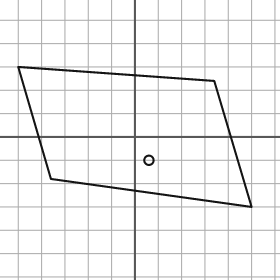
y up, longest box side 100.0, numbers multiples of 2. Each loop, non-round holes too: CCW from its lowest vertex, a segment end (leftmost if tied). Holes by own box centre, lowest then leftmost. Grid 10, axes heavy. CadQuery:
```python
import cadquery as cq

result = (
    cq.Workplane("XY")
    .moveTo(50.0, -30.0)
    .lineTo(34.0, 24.0)
    .lineTo(-50.0, 30.0)
    .lineTo(-36.0, -18.0)
    .close()
    .moveTo(6.0, -10.0)
    .circle(2.0)
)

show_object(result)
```